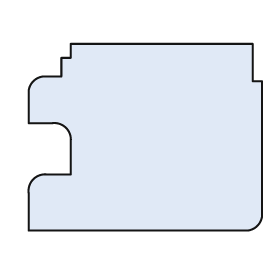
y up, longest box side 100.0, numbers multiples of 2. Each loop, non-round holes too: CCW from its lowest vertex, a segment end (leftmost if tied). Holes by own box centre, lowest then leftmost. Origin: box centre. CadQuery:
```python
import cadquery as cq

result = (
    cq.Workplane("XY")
    .moveTo(-50.0, -40.0)
    .lineTo(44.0, -40.0)
    .threePointArc((48.0, -38.0), (50.0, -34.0))
    .lineTo(50.0, 24.0)
    .lineTo(46.0, 24.0)
    .lineTo(46.0, 40.0)
    .lineTo(-32.0, 40.0)
    .lineTo(-32.0, 34.0)
    .lineTo(-36.0, 34.0)
    .lineTo(-36.0, 26.0)
    .lineTo(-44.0, 26.0)
    .threePointArc((-48.0, 24.0), (-50.0, 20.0))
    .lineTo(-50.0, 6.0)
    .lineTo(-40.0, 6.0)
    .threePointArc((-34.0, 4.0), (-32.0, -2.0))
    .lineTo(-32.0, -16.0)
    .lineTo(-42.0, -16.0)
    .threePointArc((-48.0, -18.0), (-50.0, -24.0))
    .close()
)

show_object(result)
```